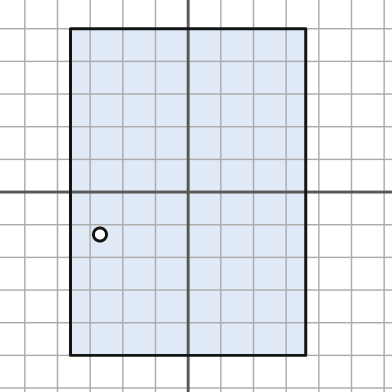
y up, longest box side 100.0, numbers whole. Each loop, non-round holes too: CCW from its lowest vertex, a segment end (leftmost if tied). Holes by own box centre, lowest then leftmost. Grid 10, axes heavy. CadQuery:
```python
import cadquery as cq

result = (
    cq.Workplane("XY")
    .moveTo(-36.0, -50.0)
    .lineTo(36.0, -50.0)
    .lineTo(36.0, 50.0)
    .lineTo(-36.0, 50.0)
    .close()
    .moveTo(-27.0, -13.0)
    .circle(2.0)
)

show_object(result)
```